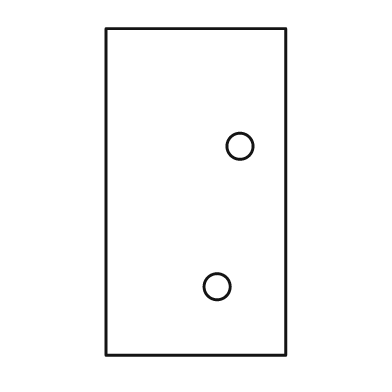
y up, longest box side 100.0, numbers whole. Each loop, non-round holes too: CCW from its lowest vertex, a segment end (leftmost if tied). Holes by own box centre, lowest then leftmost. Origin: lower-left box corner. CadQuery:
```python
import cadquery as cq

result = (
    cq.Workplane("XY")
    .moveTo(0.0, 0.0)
    .lineTo(55.0, 0.0)
    .lineTo(55.0, 100.0)
    .lineTo(0.0, 100.0)
    .close()
    .moveTo(34.0, 21.0)
    .circle(4.0)
    .moveTo(41.0, 64.0)
    .circle(4.0)
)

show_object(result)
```